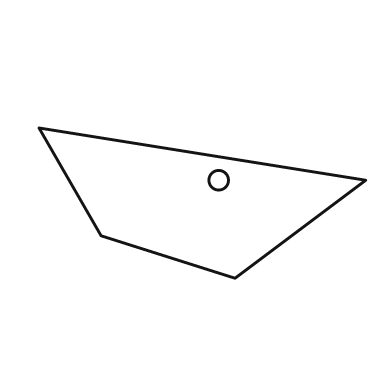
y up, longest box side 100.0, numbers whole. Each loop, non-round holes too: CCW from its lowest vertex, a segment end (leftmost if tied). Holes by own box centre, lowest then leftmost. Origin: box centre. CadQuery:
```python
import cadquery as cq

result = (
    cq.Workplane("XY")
    .moveTo(10.0, -23.0)
    .lineTo(50.0, 7.0)
    .lineTo(-50.0, 23.0)
    .lineTo(-31.0, -10.0)
    .close()
    .moveTo(5.0, 7.0)
    .circle(3.0)
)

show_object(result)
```